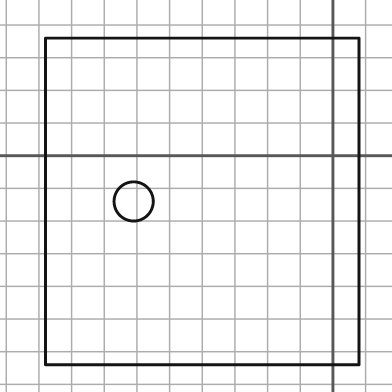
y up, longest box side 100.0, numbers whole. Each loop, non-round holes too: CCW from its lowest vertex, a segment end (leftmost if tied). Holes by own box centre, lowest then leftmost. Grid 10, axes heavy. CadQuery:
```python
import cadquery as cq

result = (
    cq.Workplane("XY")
    .moveTo(-88.0, -64.0)
    .lineTo(8.0, -64.0)
    .lineTo(8.0, 36.0)
    .lineTo(-88.0, 36.0)
    .close()
    .moveTo(-61.0, -14.0)
    .circle(6.0)
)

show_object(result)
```